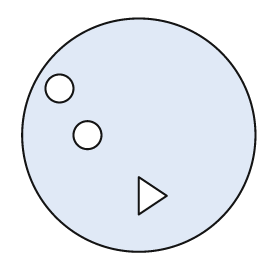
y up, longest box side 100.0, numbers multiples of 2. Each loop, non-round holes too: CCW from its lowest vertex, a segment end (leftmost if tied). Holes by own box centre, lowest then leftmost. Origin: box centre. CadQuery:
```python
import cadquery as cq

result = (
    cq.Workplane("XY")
    .moveTo(0.0, 0.0)
    .circle(50.0)
    .moveTo(0.0, -34.0)
    .lineTo(12.0, -26.0)
    .lineTo(0.0, -18.0)
    .close()
    .moveTo(-22.0, 0.0)
    .circle(6.0)
    .moveTo(-34.0, 20.0)
    .circle(6.0)
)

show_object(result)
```